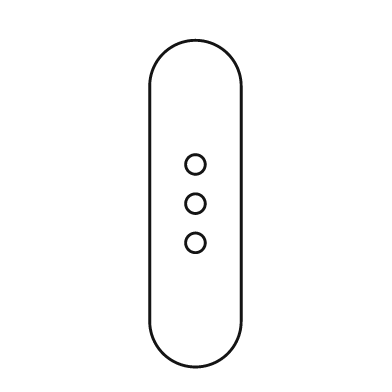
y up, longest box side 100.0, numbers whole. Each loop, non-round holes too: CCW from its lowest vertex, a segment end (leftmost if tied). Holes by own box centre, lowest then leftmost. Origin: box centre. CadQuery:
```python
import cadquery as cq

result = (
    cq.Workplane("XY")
    .moveTo(-14.0, -36.0)
    .threePointArc((0.0, -50.0), (14.0, -36.0))
    .lineTo(14.0, 36.0)
    .threePointArc((0.0, 50.0), (-14.0, 36.0))
    .close()
    .moveTo(0.0, -12.0)
    .circle(3.0)
    .moveTo(0.0, 0.0)
    .circle(3.0)
    .moveTo(0.0, 12.0)
    .circle(3.0)
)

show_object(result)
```